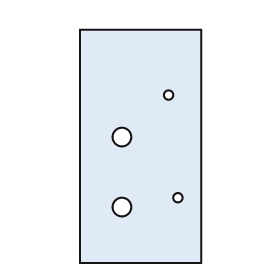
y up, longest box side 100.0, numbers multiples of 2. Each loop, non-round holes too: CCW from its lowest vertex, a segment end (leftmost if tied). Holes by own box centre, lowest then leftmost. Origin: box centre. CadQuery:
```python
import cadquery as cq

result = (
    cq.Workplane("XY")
    .moveTo(-26.0, -50.0)
    .lineTo(26.0, -50.0)
    .lineTo(26.0, 50.0)
    .lineTo(-26.0, 50.0)
    .close()
    .moveTo(-8.0, -26.0)
    .circle(4.0)
    .moveTo(16.0, -22.0)
    .circle(2.0)
    .moveTo(-8.0, 4.0)
    .circle(4.0)
    .moveTo(12.0, 22.0)
    .circle(2.0)
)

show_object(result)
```